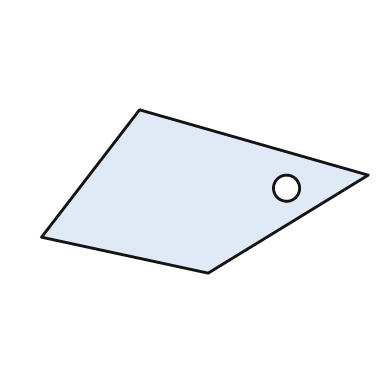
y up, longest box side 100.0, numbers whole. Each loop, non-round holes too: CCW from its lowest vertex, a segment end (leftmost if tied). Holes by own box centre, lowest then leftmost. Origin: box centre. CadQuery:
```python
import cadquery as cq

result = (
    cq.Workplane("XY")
    .moveTo(1.0, -25.0)
    .lineTo(50.0, 5.0)
    .lineTo(-20.0, 25.0)
    .lineTo(-50.0, -14.0)
    .close()
    .moveTo(25.0, 1.0)
    .circle(4.0)
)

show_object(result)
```